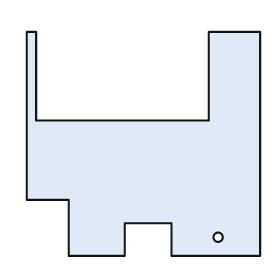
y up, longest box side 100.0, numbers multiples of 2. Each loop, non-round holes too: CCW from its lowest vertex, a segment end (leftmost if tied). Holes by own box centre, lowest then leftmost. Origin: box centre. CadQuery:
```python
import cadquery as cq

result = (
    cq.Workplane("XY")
    .moveTo(-32.0, -48.0)
    .lineTo(-8.0, -48.0)
    .lineTo(-8.0, -34.0)
    .lineTo(12.0, -34.0)
    .lineTo(12.0, -48.0)
    .lineTo(50.0, -48.0)
    .lineTo(50.0, 48.0)
    .lineTo(28.0, 48.0)
    .lineTo(28.0, 10.0)
    .lineTo(-46.0, 10.0)
    .lineTo(-46.0, 48.0)
    .lineTo(-50.0, 48.0)
    .lineTo(-50.0, -24.0)
    .lineTo(-32.0, -24.0)
    .close()
    .moveTo(32.0, -40.0)
    .circle(2.0)
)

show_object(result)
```